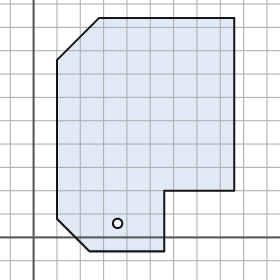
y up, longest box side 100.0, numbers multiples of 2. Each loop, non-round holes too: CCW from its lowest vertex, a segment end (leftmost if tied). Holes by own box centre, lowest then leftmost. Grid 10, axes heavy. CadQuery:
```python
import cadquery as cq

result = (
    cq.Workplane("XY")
    .moveTo(24.0, -6.0)
    .lineTo(56.0, -6.0)
    .lineTo(56.0, 20.0)
    .lineTo(86.0, 20.0)
    .lineTo(86.0, 94.0)
    .lineTo(28.0, 94.0)
    .lineTo(10.0, 76.0)
    .lineTo(10.0, 8.0)
    .close()
    .moveTo(36.0, 6.0)
    .circle(2.0)
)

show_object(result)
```